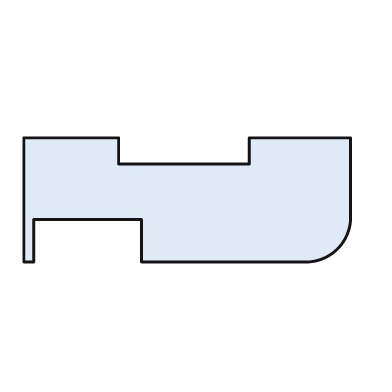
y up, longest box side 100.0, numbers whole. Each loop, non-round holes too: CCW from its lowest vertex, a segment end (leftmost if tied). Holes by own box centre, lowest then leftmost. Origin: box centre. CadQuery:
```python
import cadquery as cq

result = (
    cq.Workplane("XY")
    .moveTo(-50.0, -19.0)
    .lineTo(-47.0, -19.0)
    .lineTo(-47.0, -6.0)
    .lineTo(-14.0, -6.0)
    .lineTo(-14.0, -19.0)
    .lineTo(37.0, -19.0)
    .threePointArc((46.0, -15.0), (50.0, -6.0))
    .lineTo(50.0, 19.0)
    .lineTo(19.0, 19.0)
    .lineTo(19.0, 11.0)
    .lineTo(-21.0, 11.0)
    .lineTo(-21.0, 19.0)
    .lineTo(-50.0, 19.0)
    .close()
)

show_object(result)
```